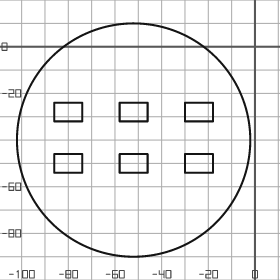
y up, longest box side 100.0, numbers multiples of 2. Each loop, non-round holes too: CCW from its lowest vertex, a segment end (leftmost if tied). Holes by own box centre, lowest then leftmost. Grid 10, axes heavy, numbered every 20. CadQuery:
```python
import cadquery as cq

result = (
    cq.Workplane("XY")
    .moveTo(-52.0, -40.0)
    .circle(50.0)
    .moveTo(-86.0, -54.0)
    .lineTo(-74.0, -54.0)
    .lineTo(-74.0, -46.0)
    .lineTo(-86.0, -46.0)
    .close()
    .moveTo(-58.0, -54.0)
    .lineTo(-46.0, -54.0)
    .lineTo(-46.0, -46.0)
    .lineTo(-58.0, -46.0)
    .close()
    .moveTo(-30.0, -54.0)
    .lineTo(-18.0, -54.0)
    .lineTo(-18.0, -46.0)
    .lineTo(-30.0, -46.0)
    .close()
    .moveTo(-86.0, -32.0)
    .lineTo(-74.0, -32.0)
    .lineTo(-74.0, -24.0)
    .lineTo(-86.0, -24.0)
    .close()
    .moveTo(-58.0, -32.0)
    .lineTo(-46.0, -32.0)
    .lineTo(-46.0, -24.0)
    .lineTo(-58.0, -24.0)
    .close()
    .moveTo(-30.0, -32.0)
    .lineTo(-18.0, -32.0)
    .lineTo(-18.0, -24.0)
    .lineTo(-30.0, -24.0)
    .close()
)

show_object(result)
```